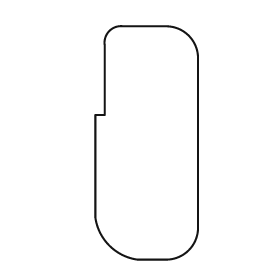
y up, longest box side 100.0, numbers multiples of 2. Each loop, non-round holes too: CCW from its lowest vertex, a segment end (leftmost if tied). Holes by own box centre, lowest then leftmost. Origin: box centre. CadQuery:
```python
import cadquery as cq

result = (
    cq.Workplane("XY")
    .moveTo(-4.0, -50.0)
    .lineTo(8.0, -50.0)
    .threePointArc((18.0, -46.0), (22.0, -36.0))
    .lineTo(22.0, 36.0)
    .threePointArc((18.0, 46.0), (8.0, 50.0))
    .lineTo(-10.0, 50.0)
    .threePointArc((-16.0, 48.0), (-18.0, 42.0))
    .lineTo(-18.0, 12.0)
    .lineTo(-22.0, 12.0)
    .lineTo(-22.0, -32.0)
    .threePointArc((-16.0, -44.0), (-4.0, -50.0))
    .close()
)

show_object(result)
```